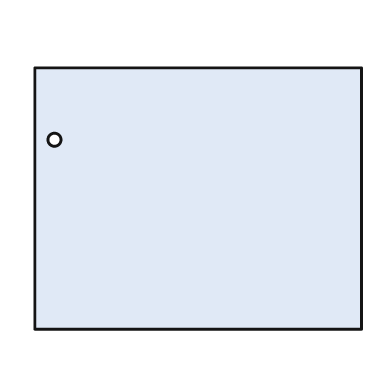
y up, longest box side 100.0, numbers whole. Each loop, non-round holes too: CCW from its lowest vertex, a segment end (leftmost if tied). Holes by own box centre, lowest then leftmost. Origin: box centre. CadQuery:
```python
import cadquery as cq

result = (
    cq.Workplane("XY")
    .moveTo(-50.0, -40.0)
    .lineTo(50.0, -40.0)
    .lineTo(50.0, 40.0)
    .lineTo(-50.0, 40.0)
    .close()
    .moveTo(-44.0, 18.0)
    .circle(2.0)
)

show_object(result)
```